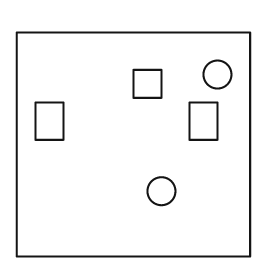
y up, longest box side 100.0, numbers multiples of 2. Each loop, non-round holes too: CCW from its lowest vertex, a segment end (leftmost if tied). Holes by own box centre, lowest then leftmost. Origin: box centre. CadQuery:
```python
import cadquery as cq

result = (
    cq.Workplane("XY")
    .moveTo(-50.0, -48.0)
    .lineTo(50.0, -48.0)
    .lineTo(50.0, 48.0)
    .lineTo(-50.0, 48.0)
    .close()
    .moveTo(12.0, -20.0)
    .circle(6.0)
    .moveTo(-42.0, 2.0)
    .lineTo(-30.0, 2.0)
    .lineTo(-30.0, 18.0)
    .lineTo(-42.0, 18.0)
    .close()
    .moveTo(24.0, 2.0)
    .lineTo(36.0, 2.0)
    .lineTo(36.0, 18.0)
    .lineTo(24.0, 18.0)
    .close()
    .moveTo(0.0, 20.0)
    .lineTo(12.0, 20.0)
    .lineTo(12.0, 32.0)
    .lineTo(0.0, 32.0)
    .close()
    .moveTo(36.0, 30.0)
    .circle(6.0)
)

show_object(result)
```